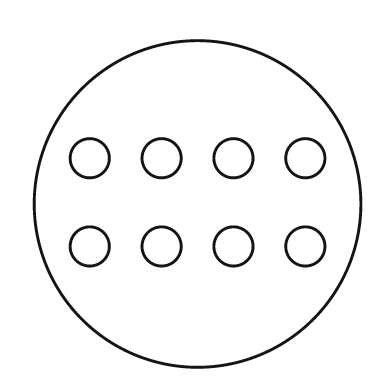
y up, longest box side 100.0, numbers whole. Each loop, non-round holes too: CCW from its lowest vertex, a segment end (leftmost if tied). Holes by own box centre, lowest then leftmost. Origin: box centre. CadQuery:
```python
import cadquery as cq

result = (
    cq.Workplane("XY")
    .moveTo(0.0, 0.0)
    .circle(50.0)
    .moveTo(-33.0, -13.0)
    .circle(6.0)
    .moveTo(-11.0, -13.0)
    .circle(6.0)
    .moveTo(11.0, -13.0)
    .circle(6.0)
    .moveTo(33.0, -13.0)
    .circle(6.0)
    .moveTo(-33.0, 14.0)
    .circle(6.0)
    .moveTo(-11.0, 14.0)
    .circle(6.0)
    .moveTo(11.0, 14.0)
    .circle(6.0)
    .moveTo(33.0, 14.0)
    .circle(6.0)
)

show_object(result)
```